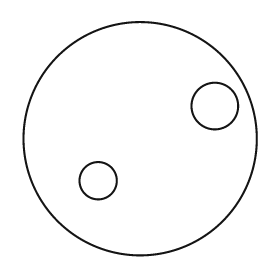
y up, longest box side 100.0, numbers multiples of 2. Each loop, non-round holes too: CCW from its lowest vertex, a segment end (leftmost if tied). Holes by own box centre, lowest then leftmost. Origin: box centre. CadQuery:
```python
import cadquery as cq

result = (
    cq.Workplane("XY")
    .moveTo(0.0, 0.0)
    .circle(50.0)
    .moveTo(-18.0, -18.0)
    .circle(8.0)
    .moveTo(32.0, 14.0)
    .circle(10.0)
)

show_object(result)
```